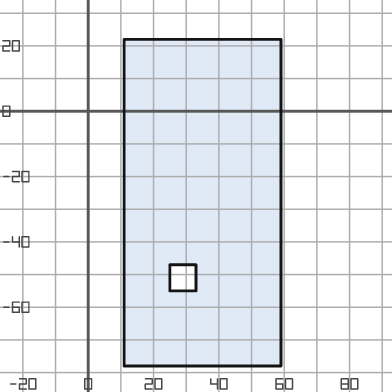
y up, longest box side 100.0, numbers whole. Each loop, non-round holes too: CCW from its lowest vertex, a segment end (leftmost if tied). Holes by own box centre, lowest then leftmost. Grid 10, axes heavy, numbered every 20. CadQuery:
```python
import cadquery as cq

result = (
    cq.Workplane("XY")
    .moveTo(11.0, -78.0)
    .lineTo(59.0, -78.0)
    .lineTo(59.0, 22.0)
    .lineTo(11.0, 22.0)
    .close()
    .moveTo(25.0, -55.0)
    .lineTo(33.0, -55.0)
    .lineTo(33.0, -47.0)
    .lineTo(25.0, -47.0)
    .close()
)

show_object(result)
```